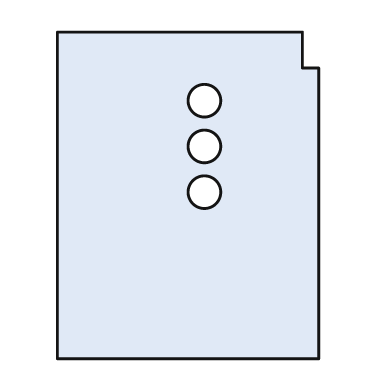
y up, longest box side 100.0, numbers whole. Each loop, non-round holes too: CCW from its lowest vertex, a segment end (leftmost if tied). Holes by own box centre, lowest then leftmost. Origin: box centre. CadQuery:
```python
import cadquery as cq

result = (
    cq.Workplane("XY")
    .moveTo(-40.0, -50.0)
    .lineTo(40.0, -50.0)
    .lineTo(40.0, 39.0)
    .lineTo(35.0, 39.0)
    .lineTo(35.0, 50.0)
    .lineTo(-40.0, 50.0)
    .close()
    .moveTo(5.0, 1.0)
    .circle(5.0)
    .moveTo(5.0, 15.0)
    .circle(5.0)
    .moveTo(5.0, 29.0)
    .circle(5.0)
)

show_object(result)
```